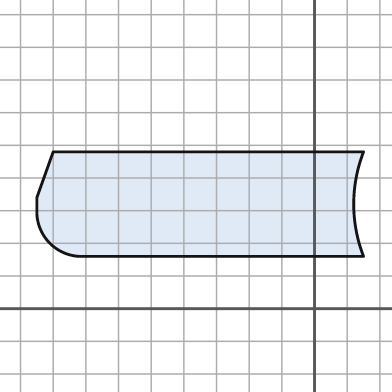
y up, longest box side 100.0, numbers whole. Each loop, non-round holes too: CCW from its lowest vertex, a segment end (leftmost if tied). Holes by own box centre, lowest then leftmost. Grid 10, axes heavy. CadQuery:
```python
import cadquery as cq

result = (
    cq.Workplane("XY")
    .moveTo(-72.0, 16.0)
    .lineTo(15.0, 16.0)
    .threePointArc((12.0, 32.0), (15.0, 48.0))
    .lineTo(-80.0, 48.0)
    .lineTo(-85.0, 34.0)
    .lineTo(-85.0, 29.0)
    .threePointArc((-81.0, 20.0), (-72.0, 16.0))
    .close()
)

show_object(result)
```